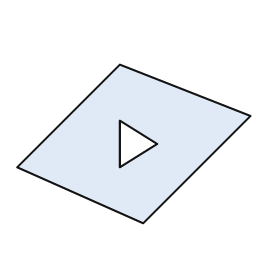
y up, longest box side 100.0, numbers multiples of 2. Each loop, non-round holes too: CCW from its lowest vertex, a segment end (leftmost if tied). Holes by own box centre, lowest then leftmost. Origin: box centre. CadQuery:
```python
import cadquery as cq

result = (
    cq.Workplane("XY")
    .moveTo(4.0, -34.0)
    .lineTo(50.0, 12.0)
    .lineTo(-6.0, 34.0)
    .lineTo(-50.0, -10.0)
    .close()
    .moveTo(-6.0, -10.0)
    .lineTo(10.0, 0.0)
    .lineTo(-6.0, 10.0)
    .close()
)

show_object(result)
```